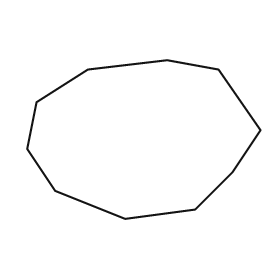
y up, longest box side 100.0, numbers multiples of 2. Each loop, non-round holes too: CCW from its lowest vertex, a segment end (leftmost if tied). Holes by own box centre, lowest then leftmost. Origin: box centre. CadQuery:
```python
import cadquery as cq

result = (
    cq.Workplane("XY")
    .moveTo(-8.0, -34.0)
    .lineTo(22.0, -30.0)
    .lineTo(38.0, -14.0)
    .lineTo(50.0, 4.0)
    .lineTo(32.0, 30.0)
    .lineTo(10.0, 34.0)
    .lineTo(-24.0, 30.0)
    .lineTo(-46.0, 16.0)
    .lineTo(-50.0, -4.0)
    .lineTo(-38.0, -22.0)
    .close()
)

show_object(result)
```